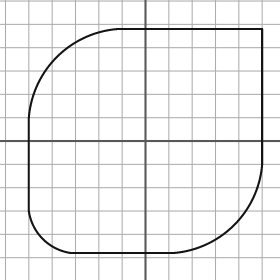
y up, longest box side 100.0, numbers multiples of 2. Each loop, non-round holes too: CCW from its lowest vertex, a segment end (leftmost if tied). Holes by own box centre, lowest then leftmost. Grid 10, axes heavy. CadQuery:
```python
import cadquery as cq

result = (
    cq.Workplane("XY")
    .moveTo(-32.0, -48.0)
    .lineTo(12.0, -48.0)
    .threePointArc((38.0, -36.0), (50.0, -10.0))
    .lineTo(50.0, 48.0)
    .lineTo(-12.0, 48.0)
    .threePointArc((-38.0, 36.0), (-50.0, 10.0))
    .lineTo(-50.0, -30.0)
    .threePointArc((-44.0, -42.0), (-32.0, -48.0))
    .close()
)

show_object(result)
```